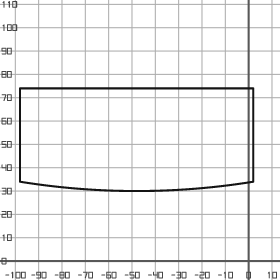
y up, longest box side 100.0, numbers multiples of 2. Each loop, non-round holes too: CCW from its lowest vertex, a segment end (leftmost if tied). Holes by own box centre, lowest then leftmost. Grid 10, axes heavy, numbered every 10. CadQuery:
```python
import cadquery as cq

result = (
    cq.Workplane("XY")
    .moveTo(-98.0, 34.0)
    .threePointArc((-48.0, 30.0), (2.0, 34.0))
    .lineTo(2.0, 74.0)
    .lineTo(-98.0, 74.0)
    .close()
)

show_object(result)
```